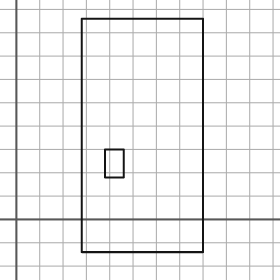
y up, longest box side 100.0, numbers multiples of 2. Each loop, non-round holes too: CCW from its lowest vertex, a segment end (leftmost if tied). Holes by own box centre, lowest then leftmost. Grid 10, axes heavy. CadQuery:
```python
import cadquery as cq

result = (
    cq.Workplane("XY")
    .moveTo(28.0, -14.0)
    .lineTo(80.0, -14.0)
    .lineTo(80.0, 86.0)
    .lineTo(28.0, 86.0)
    .close()
    .moveTo(38.0, 18.0)
    .lineTo(46.0, 18.0)
    .lineTo(46.0, 30.0)
    .lineTo(38.0, 30.0)
    .close()
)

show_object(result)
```